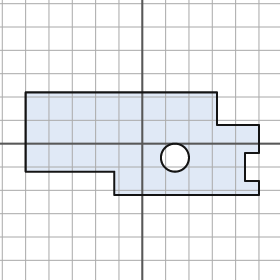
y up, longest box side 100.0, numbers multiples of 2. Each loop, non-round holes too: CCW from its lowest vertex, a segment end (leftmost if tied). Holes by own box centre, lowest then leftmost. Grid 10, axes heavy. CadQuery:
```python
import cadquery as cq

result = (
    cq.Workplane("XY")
    .moveTo(-12.0, -22.0)
    .lineTo(50.0, -22.0)
    .lineTo(50.0, -16.0)
    .lineTo(44.0, -16.0)
    .lineTo(44.0, -4.0)
    .lineTo(50.0, -4.0)
    .lineTo(50.0, 8.0)
    .lineTo(32.0, 8.0)
    .lineTo(32.0, 22.0)
    .lineTo(-50.0, 22.0)
    .lineTo(-50.0, -12.0)
    .lineTo(-12.0, -12.0)
    .close()
    .moveTo(14.0, -6.0)
    .circle(6.0)
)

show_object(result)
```